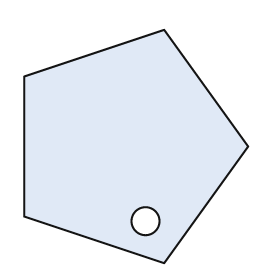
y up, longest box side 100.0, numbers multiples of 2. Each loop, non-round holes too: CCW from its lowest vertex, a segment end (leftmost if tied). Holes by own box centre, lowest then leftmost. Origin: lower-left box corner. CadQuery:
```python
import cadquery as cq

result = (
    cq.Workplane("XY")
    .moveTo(60.0, 0.0)
    .lineTo(96.0, 50.0)
    .lineTo(60.0, 100.0)
    .lineTo(0.0, 80.0)
    .lineTo(0.0, 20.0)
    .close()
    .moveTo(52.0, 18.0)
    .circle(6.0)
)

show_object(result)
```